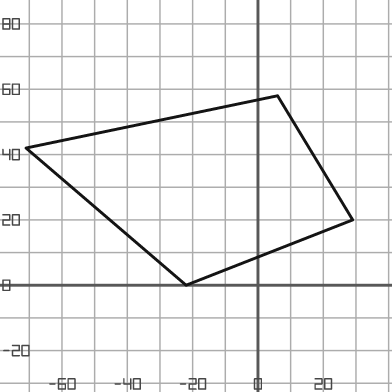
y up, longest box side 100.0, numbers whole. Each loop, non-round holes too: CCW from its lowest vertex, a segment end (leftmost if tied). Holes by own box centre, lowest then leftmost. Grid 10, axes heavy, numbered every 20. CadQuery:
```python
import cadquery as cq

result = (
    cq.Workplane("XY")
    .moveTo(-22.0, 0.0)
    .lineTo(29.0, 20.0)
    .lineTo(6.0, 58.0)
    .lineTo(-71.0, 42.0)
    .close()
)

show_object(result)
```